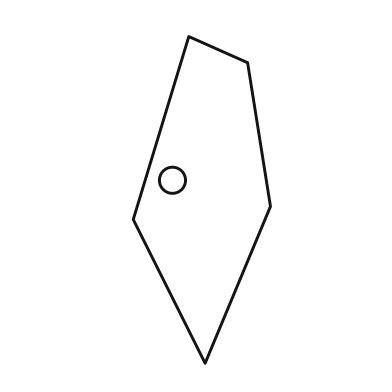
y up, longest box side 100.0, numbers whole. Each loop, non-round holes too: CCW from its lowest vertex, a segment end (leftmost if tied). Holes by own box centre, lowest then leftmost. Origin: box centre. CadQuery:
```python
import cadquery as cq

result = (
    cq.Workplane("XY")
    .moveTo(1.0, -50.0)
    .lineTo(21.0, -2.0)
    .lineTo(14.0, 42.0)
    .lineTo(-4.0, 50.0)
    .lineTo(-21.0, -6.0)
    .close()
    .moveTo(-9.0, 6.0)
    .circle(4.0)
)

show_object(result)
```